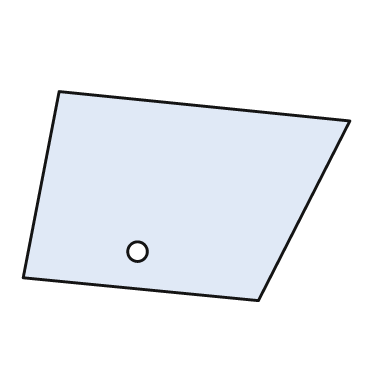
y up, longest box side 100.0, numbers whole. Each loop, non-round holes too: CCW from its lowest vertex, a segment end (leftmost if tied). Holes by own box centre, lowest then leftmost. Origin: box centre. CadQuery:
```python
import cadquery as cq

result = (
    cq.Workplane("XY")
    .moveTo(22.0, -32.0)
    .lineTo(50.0, 23.0)
    .lineTo(-39.0, 32.0)
    .lineTo(-50.0, -25.0)
    .close()
    .moveTo(-15.0, -17.0)
    .circle(3.0)
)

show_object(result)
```